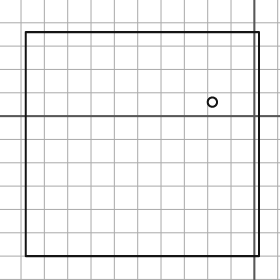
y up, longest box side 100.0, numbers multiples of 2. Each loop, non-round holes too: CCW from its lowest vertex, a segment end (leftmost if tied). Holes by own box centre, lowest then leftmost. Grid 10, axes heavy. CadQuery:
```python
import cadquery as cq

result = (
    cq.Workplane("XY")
    .moveTo(-98.0, -60.0)
    .lineTo(2.0, -60.0)
    .lineTo(2.0, 36.0)
    .lineTo(-98.0, 36.0)
    .close()
    .moveTo(-18.0, 6.0)
    .circle(2.0)
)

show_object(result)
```